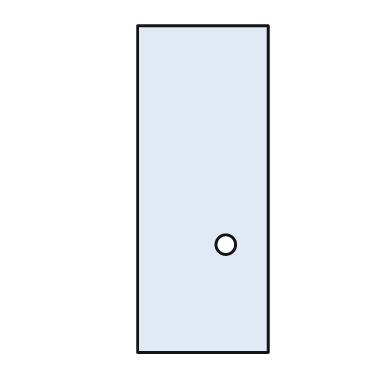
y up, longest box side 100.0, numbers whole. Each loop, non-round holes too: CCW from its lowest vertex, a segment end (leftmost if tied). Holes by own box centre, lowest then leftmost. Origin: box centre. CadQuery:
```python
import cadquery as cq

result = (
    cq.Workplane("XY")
    .moveTo(-20.0, -50.0)
    .lineTo(20.0, -50.0)
    .lineTo(20.0, 50.0)
    .lineTo(-20.0, 50.0)
    .close()
    .moveTo(7.0, -17.0)
    .circle(3.0)
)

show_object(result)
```